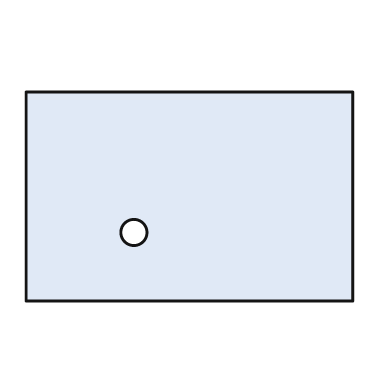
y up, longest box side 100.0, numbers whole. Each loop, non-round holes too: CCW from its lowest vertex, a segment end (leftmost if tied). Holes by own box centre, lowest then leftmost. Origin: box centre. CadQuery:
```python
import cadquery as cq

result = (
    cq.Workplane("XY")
    .moveTo(-50.0, -32.0)
    .lineTo(50.0, -32.0)
    .lineTo(50.0, 32.0)
    .lineTo(-50.0, 32.0)
    .close()
    .moveTo(-17.0, -11.0)
    .circle(4.0)
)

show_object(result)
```